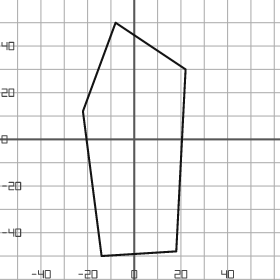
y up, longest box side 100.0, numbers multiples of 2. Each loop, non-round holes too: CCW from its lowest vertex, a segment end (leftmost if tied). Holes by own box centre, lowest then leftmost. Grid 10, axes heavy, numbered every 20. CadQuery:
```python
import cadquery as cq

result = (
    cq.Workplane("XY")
    .moveTo(-14.0, -50.0)
    .lineTo(18.0, -48.0)
    .lineTo(22.0, 30.0)
    .lineTo(-8.0, 50.0)
    .lineTo(-22.0, 12.0)
    .close()
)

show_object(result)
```